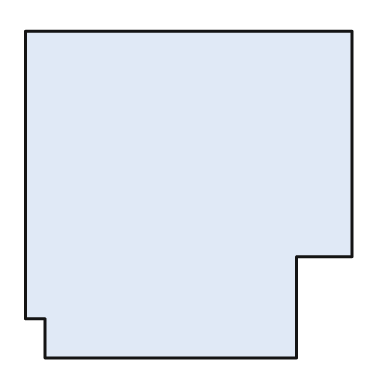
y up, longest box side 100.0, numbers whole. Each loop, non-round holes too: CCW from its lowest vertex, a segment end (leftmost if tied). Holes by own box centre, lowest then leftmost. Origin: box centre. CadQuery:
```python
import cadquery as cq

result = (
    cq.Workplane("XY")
    .moveTo(-44.0, -50.0)
    .lineTo(33.0, -50.0)
    .lineTo(33.0, -19.0)
    .lineTo(50.0, -19.0)
    .lineTo(50.0, 50.0)
    .lineTo(-50.0, 50.0)
    .lineTo(-50.0, -38.0)
    .lineTo(-44.0, -38.0)
    .close()
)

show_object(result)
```